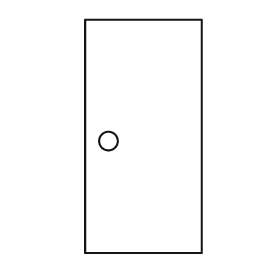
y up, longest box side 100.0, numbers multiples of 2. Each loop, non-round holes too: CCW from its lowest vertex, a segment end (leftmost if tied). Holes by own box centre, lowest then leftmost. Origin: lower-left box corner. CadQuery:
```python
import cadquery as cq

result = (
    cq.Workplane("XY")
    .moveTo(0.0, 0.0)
    .lineTo(50.0, 0.0)
    .lineTo(50.0, 100.0)
    .lineTo(0.0, 100.0)
    .close()
    .moveTo(10.0, 48.0)
    .circle(4.0)
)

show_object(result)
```